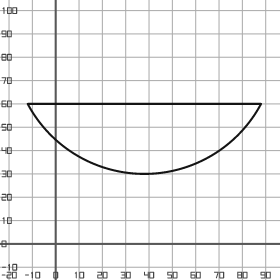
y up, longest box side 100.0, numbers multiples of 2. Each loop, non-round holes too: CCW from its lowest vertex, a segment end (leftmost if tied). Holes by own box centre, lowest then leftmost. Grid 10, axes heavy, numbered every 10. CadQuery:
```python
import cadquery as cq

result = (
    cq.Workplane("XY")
    .moveTo(-12.0, 60.0)
    .threePointArc((38.0, 30.0), (88.0, 60.0))
    .close()
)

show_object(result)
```